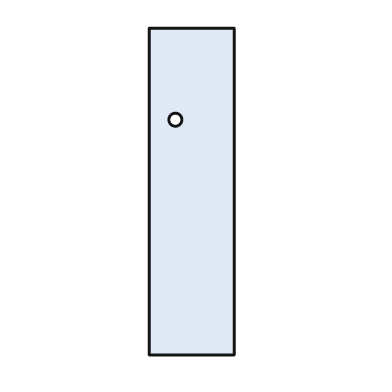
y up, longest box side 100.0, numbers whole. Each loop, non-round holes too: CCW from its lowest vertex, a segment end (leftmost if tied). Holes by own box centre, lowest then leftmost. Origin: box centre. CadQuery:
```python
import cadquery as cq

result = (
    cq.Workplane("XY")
    .moveTo(-13.0, -50.0)
    .lineTo(13.0, -50.0)
    .lineTo(13.0, 50.0)
    .lineTo(-13.0, 50.0)
    .close()
    .moveTo(-5.0, 22.0)
    .circle(2.0)
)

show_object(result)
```